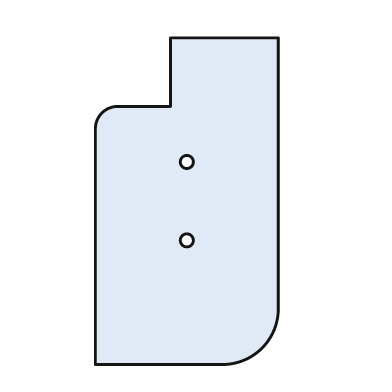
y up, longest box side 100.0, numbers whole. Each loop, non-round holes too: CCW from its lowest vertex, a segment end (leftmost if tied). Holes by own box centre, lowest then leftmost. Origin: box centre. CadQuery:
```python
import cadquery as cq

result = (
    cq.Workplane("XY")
    .moveTo(-28.0, -50.0)
    .lineTo(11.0, -50.0)
    .threePointArc((23.0, -45.0), (28.0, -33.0))
    .lineTo(28.0, 50.0)
    .lineTo(-5.0, 50.0)
    .lineTo(-5.0, 29.0)
    .lineTo(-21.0, 29.0)
    .threePointArc((-26.0, 27.0), (-28.0, 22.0))
    .close()
    .moveTo(0.0, -12.0)
    .circle(2.0)
    .moveTo(0.0, 12.0)
    .circle(2.0)
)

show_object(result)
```